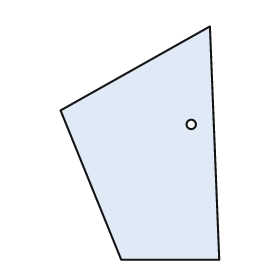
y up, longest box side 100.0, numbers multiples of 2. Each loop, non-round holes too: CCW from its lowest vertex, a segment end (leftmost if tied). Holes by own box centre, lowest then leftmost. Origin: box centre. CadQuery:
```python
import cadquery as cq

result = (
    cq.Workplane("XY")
    .moveTo(-8.0, -50.0)
    .lineTo(34.0, -50.0)
    .lineTo(30.0, 50.0)
    .lineTo(-34.0, 14.0)
    .close()
    .moveTo(22.0, 8.0)
    .circle(2.0)
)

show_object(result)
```